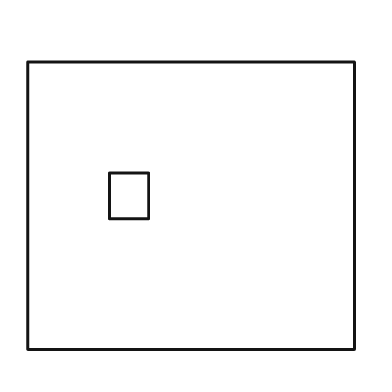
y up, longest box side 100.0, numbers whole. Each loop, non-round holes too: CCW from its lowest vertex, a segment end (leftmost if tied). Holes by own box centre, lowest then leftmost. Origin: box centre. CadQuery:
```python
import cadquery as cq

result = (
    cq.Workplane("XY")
    .moveTo(-50.0, -44.0)
    .lineTo(50.0, -44.0)
    .lineTo(50.0, 44.0)
    .lineTo(-50.0, 44.0)
    .close()
    .moveTo(-25.0, -4.0)
    .lineTo(-13.0, -4.0)
    .lineTo(-13.0, 10.0)
    .lineTo(-25.0, 10.0)
    .close()
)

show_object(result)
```